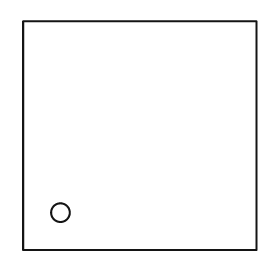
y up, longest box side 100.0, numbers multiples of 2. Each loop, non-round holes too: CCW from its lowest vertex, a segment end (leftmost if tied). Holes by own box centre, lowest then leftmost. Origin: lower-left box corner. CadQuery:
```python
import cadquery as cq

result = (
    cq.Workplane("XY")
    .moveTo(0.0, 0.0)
    .lineTo(100.0, 0.0)
    .lineTo(100.0, 98.0)
    .lineTo(0.0, 98.0)
    .close()
    .moveTo(16.0, 16.0)
    .circle(4.0)
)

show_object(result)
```